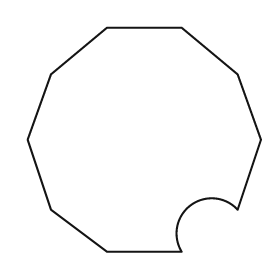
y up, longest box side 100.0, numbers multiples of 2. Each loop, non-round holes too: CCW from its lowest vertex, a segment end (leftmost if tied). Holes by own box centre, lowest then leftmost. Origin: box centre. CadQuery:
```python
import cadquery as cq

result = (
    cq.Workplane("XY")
    .moveTo(-16.0, -48.0)
    .lineTo(16.0, -48.0)
    .threePointArc((20.0, -28.0), (40.0, -30.0))
    .lineTo(50.0, 0.0)
    .lineTo(40.0, 28.0)
    .lineTo(16.0, 48.0)
    .lineTo(-16.0, 48.0)
    .lineTo(-40.0, 28.0)
    .lineTo(-50.0, 0.0)
    .lineTo(-40.0, -30.0)
    .close()
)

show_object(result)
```